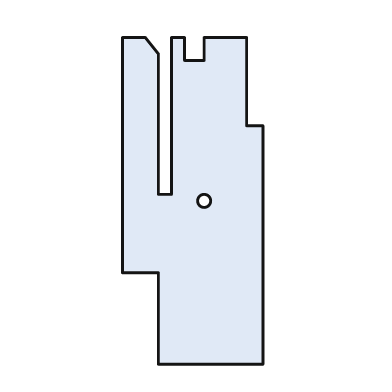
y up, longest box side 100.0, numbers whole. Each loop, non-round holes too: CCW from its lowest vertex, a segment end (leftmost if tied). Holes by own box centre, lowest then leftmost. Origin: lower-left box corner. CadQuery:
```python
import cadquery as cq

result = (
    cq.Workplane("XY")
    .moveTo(11.0, 0.0)
    .lineTo(43.0, 0.0)
    .lineTo(43.0, 73.0)
    .lineTo(38.0, 73.0)
    .lineTo(38.0, 100.0)
    .lineTo(25.0, 100.0)
    .lineTo(25.0, 93.0)
    .lineTo(19.0, 93.0)
    .lineTo(19.0, 100.0)
    .lineTo(15.0, 100.0)
    .lineTo(15.0, 52.0)
    .lineTo(11.0, 52.0)
    .lineTo(11.0, 95.0)
    .lineTo(7.0, 100.0)
    .lineTo(0.0, 100.0)
    .lineTo(0.0, 28.0)
    .lineTo(11.0, 28.0)
    .close()
    .moveTo(25.0, 50.0)
    .circle(2.0)
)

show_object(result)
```